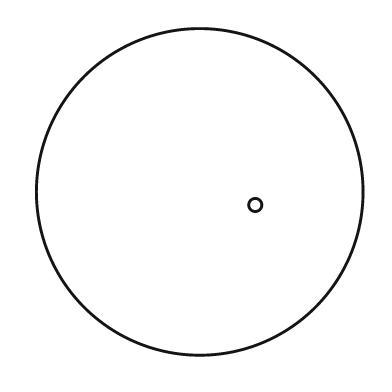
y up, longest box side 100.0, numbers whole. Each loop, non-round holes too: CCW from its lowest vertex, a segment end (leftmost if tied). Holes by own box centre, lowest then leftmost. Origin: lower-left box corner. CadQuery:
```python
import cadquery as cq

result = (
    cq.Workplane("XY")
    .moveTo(50.0, 50.0)
    .circle(50.0)
    .moveTo(67.0, 46.0)
    .circle(2.0)
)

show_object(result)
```